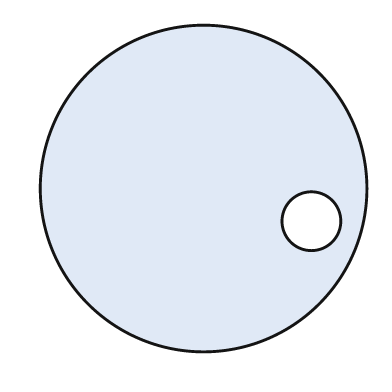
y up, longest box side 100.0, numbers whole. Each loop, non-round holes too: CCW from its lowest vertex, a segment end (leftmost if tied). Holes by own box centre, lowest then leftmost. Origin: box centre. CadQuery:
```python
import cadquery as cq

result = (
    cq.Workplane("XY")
    .moveTo(0.0, 0.0)
    .circle(50.0)
    .moveTo(33.0, -10.0)
    .circle(9.0)
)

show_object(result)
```